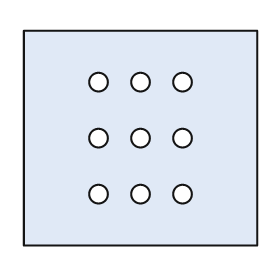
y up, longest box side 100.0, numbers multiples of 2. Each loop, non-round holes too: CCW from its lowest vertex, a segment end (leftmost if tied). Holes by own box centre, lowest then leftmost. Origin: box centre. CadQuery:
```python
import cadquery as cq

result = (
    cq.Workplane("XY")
    .moveTo(-50.0, -46.0)
    .lineTo(50.0, -46.0)
    .lineTo(50.0, 46.0)
    .lineTo(-50.0, 46.0)
    .close()
    .moveTo(-18.0, -24.0)
    .circle(4.0)
    .moveTo(0.0, -24.0)
    .circle(4.0)
    .moveTo(18.0, -24.0)
    .circle(4.0)
    .moveTo(-18.0, 0.0)
    .circle(4.0)
    .moveTo(0.0, 0.0)
    .circle(4.0)
    .moveTo(18.0, 0.0)
    .circle(4.0)
    .moveTo(-18.0, 24.0)
    .circle(4.0)
    .moveTo(0.0, 24.0)
    .circle(4.0)
    .moveTo(18.0, 24.0)
    .circle(4.0)
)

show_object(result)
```